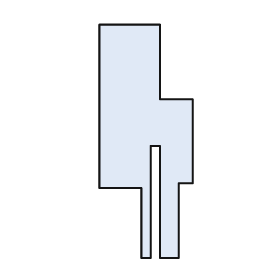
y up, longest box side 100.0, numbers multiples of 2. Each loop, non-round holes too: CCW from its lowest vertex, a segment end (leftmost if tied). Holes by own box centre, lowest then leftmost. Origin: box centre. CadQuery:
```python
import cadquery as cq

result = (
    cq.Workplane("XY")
    .moveTo(-2.0, -50.0)
    .lineTo(2.0, -50.0)
    .lineTo(2.0, -2.0)
    .lineTo(6.0, -2.0)
    .lineTo(6.0, -50.0)
    .lineTo(14.0, -50.0)
    .lineTo(14.0, -18.0)
    .lineTo(20.0, -18.0)
    .lineTo(20.0, 18.0)
    .lineTo(6.0, 18.0)
    .lineTo(6.0, 50.0)
    .lineTo(-20.0, 50.0)
    .lineTo(-20.0, -20.0)
    .lineTo(-2.0, -20.0)
    .close()
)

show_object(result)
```